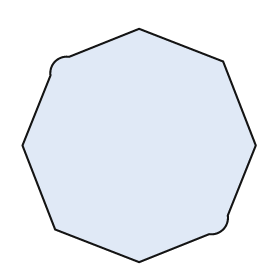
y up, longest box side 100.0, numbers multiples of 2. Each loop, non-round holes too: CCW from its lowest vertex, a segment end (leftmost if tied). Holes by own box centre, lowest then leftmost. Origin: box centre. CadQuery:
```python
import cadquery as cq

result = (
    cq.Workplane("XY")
    .moveTo(0.0, -50.0)
    .lineTo(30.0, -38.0)
    .threePointArc((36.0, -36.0), (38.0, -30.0))
    .lineTo(50.0, 0.0)
    .lineTo(36.0, 36.0)
    .lineTo(0.0, 50.0)
    .lineTo(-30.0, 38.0)
    .threePointArc((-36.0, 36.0), (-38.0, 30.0))
    .lineTo(-50.0, 0.0)
    .lineTo(-36.0, -36.0)
    .close()
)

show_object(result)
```